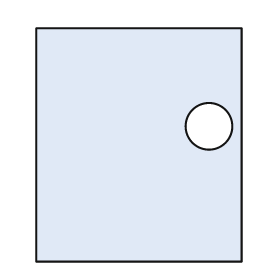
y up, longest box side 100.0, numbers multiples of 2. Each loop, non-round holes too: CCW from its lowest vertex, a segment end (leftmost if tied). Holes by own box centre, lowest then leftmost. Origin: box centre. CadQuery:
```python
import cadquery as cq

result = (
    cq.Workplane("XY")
    .moveTo(-44.0, -50.0)
    .lineTo(44.0, -50.0)
    .lineTo(44.0, 50.0)
    .lineTo(-44.0, 50.0)
    .close()
    .moveTo(30.0, 8.0)
    .circle(10.0)
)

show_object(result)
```